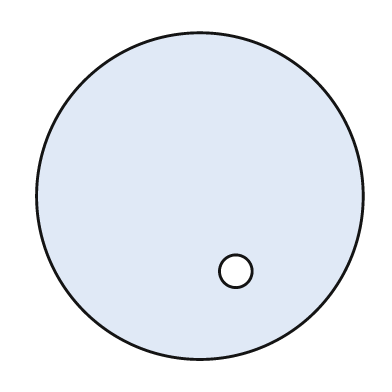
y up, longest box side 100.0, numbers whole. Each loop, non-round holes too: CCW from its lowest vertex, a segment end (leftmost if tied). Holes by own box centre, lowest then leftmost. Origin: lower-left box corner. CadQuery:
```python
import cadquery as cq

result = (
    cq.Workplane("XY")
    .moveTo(50.0, 50.0)
    .circle(50.0)
    .moveTo(61.0, 27.0)
    .circle(5.0)
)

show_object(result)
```